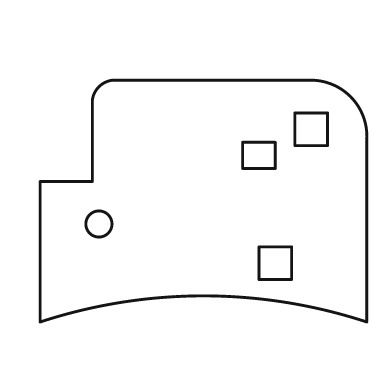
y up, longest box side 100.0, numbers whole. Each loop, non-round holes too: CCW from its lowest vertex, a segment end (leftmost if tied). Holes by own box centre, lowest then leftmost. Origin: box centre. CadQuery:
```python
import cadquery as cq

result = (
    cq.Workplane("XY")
    .moveTo(-50.0, -37.0)
    .threePointArc((0.0, -29.0), (50.0, -37.0))
    .lineTo(50.0, 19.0)
    .threePointArc((45.0, 32.0), (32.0, 37.0))
    .lineTo(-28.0, 37.0)
    .threePointArc((-32.0, 35.0), (-34.0, 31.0))
    .lineTo(-34.0, 6.0)
    .lineTo(-50.0, 6.0)
    .close()
    .moveTo(17.0, -24.0)
    .lineTo(27.0, -24.0)
    .lineTo(27.0, -14.0)
    .lineTo(17.0, -14.0)
    .close()
    .moveTo(-32.0, -7.0)
    .circle(4.0)
    .moveTo(12.0, 10.0)
    .lineTo(22.0, 10.0)
    .lineTo(22.0, 18.0)
    .lineTo(12.0, 18.0)
    .close()
    .moveTo(28.0, 17.0)
    .lineTo(38.0, 17.0)
    .lineTo(38.0, 27.0)
    .lineTo(28.0, 27.0)
    .close()
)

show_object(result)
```